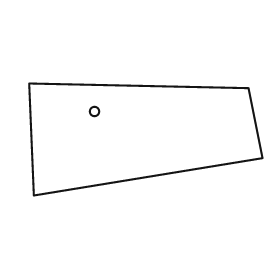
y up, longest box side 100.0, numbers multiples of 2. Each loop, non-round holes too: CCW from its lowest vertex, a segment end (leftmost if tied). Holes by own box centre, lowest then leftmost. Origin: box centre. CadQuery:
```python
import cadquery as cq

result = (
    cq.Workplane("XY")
    .moveTo(-48.0, -24.0)
    .lineTo(50.0, -8.0)
    .lineTo(44.0, 22.0)
    .lineTo(-50.0, 24.0)
    .close()
    .moveTo(-22.0, 12.0)
    .circle(2.0)
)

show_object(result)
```